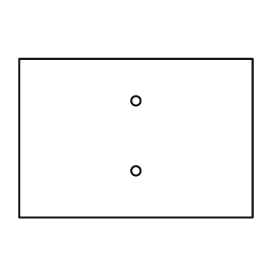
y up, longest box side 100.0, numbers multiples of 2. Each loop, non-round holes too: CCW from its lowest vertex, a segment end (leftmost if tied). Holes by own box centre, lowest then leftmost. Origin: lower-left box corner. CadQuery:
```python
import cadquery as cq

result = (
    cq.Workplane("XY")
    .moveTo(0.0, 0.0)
    .lineTo(100.0, 0.0)
    .lineTo(100.0, 68.0)
    .lineTo(0.0, 68.0)
    .close()
    .moveTo(50.0, 20.0)
    .circle(2.0)
    .moveTo(50.0, 50.0)
    .circle(2.0)
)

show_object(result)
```